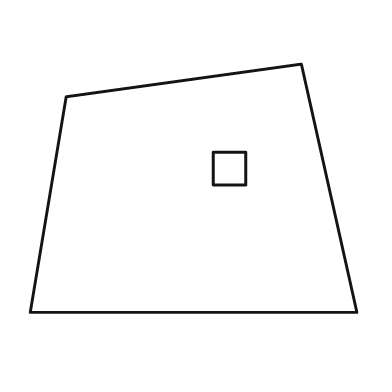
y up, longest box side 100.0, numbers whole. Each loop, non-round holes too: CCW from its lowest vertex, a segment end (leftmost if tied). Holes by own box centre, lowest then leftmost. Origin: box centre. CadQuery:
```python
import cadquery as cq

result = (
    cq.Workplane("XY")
    .moveTo(-50.0, -38.0)
    .lineTo(50.0, -38.0)
    .lineTo(33.0, 38.0)
    .lineTo(-39.0, 28.0)
    .close()
    .moveTo(6.0, 1.0)
    .lineTo(16.0, 1.0)
    .lineTo(16.0, 11.0)
    .lineTo(6.0, 11.0)
    .close()
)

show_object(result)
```